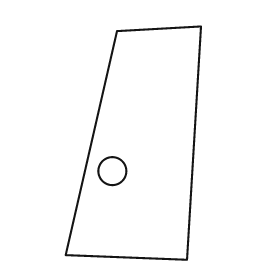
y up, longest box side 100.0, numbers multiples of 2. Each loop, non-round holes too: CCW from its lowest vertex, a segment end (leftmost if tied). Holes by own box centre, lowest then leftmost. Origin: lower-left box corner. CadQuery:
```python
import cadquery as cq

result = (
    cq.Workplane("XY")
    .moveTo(52.0, 0.0)
    .lineTo(58.0, 100.0)
    .lineTo(22.0, 98.0)
    .lineTo(0.0, 2.0)
    .close()
    .moveTo(20.0, 38.0)
    .circle(6.0)
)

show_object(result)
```